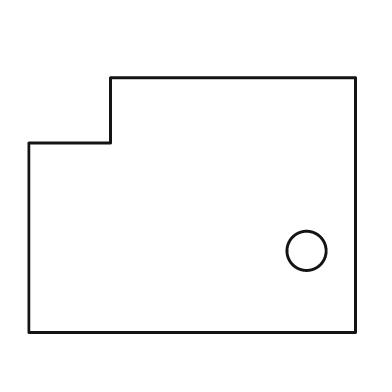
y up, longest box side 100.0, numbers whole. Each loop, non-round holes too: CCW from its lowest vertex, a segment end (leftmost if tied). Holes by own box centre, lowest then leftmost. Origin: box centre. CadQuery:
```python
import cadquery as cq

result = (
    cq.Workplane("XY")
    .moveTo(-50.0, -39.0)
    .lineTo(50.0, -39.0)
    .lineTo(50.0, 39.0)
    .lineTo(-25.0, 39.0)
    .lineTo(-25.0, 19.0)
    .lineTo(-50.0, 19.0)
    .close()
    .moveTo(35.0, -14.0)
    .circle(6.0)
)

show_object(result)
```